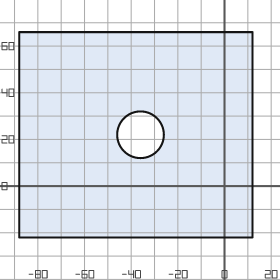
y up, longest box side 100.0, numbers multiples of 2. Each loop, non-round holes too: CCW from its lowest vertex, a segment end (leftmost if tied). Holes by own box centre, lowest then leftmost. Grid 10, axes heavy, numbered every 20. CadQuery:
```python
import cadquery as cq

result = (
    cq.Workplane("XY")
    .moveTo(-88.0, -22.0)
    .lineTo(12.0, -22.0)
    .lineTo(12.0, 66.0)
    .lineTo(-88.0, 66.0)
    .close()
    .moveTo(-36.0, 22.0)
    .circle(10.0)
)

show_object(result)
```